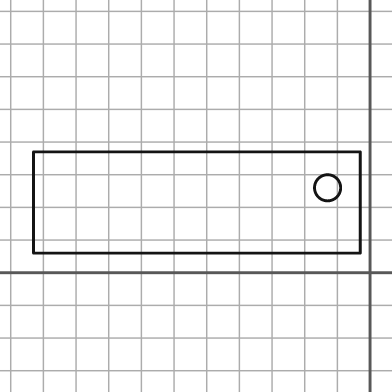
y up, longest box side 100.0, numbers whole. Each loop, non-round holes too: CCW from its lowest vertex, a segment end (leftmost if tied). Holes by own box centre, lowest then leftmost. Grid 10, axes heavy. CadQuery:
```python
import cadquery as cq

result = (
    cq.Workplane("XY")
    .moveTo(-103.0, 6.0)
    .lineTo(-3.0, 6.0)
    .lineTo(-3.0, 37.0)
    .lineTo(-103.0, 37.0)
    .close()
    .moveTo(-13.0, 26.0)
    .circle(4.0)
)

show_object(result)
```